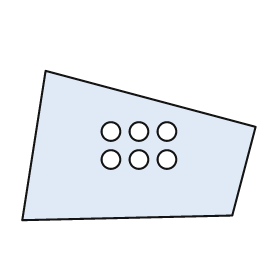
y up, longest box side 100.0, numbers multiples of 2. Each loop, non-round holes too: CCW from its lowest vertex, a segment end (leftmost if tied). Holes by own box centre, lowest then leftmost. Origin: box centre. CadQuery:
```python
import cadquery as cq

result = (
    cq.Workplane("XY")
    .moveTo(-50.0, -32.0)
    .lineTo(40.0, -30.0)
    .lineTo(50.0, 8.0)
    .lineTo(-40.0, 32.0)
    .close()
    .moveTo(-12.0, -6.0)
    .circle(4.0)
    .moveTo(0.0, -6.0)
    .circle(4.0)
    .moveTo(12.0, -6.0)
    .circle(4.0)
    .moveTo(-12.0, 6.0)
    .circle(4.0)
    .moveTo(0.0, 6.0)
    .circle(4.0)
    .moveTo(12.0, 6.0)
    .circle(4.0)
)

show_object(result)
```